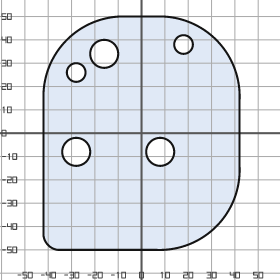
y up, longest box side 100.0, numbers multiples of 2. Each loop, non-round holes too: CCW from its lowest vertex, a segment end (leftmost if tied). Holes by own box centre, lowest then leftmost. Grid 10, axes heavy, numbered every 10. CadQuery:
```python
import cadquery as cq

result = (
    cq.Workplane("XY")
    .moveTo(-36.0, -50.0)
    .lineTo(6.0, -50.0)
    .threePointArc((32.0, -40.0), (42.0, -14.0))
    .lineTo(42.0, 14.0)
    .threePointArc((32.0, 40.0), (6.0, 50.0))
    .lineTo(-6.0, 50.0)
    .threePointArc((-32.0, 40.0), (-42.0, 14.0))
    .lineTo(-42.0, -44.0)
    .threePointArc((-40.0, -48.0), (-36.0, -50.0))
    .close()
    .moveTo(-28.0, -8.0)
    .circle(6.0)
    .moveTo(8.0, -8.0)
    .circle(6.0)
    .moveTo(-28.0, 26.0)
    .circle(4.0)
    .moveTo(-16.0, 34.0)
    .circle(6.0)
    .moveTo(18.0, 38.0)
    .circle(4.0)
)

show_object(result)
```